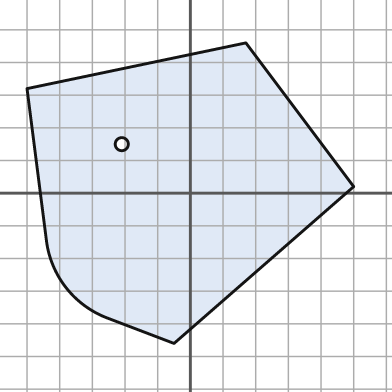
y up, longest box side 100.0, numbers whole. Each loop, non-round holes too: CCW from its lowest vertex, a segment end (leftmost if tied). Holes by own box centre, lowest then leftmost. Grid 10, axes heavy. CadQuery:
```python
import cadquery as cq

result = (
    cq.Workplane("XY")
    .moveTo(-5.0, -46.0)
    .lineTo(50.0, 2.0)
    .lineTo(17.0, 46.0)
    .lineTo(-50.0, 32.0)
    .lineTo(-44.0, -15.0)
    .threePointArc((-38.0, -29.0), (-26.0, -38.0))
    .close()
    .moveTo(-21.0, 15.0)
    .circle(2.0)
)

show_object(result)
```